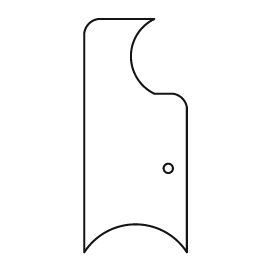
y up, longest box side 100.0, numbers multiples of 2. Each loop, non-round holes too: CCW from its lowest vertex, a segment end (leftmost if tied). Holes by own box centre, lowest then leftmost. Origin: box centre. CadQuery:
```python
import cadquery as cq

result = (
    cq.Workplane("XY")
    .moveTo(-22.0, -50.0)
    .threePointArc((0.0, -38.0), (22.0, -50.0))
    .lineTo(22.0, 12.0)
    .threePointArc((20.0, 16.0), (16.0, 18.0))
    .lineTo(8.0, 18.0)
    .threePointArc((-2.0, 34.0), (8.0, 50.0))
    .lineTo(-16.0, 50.0)
    .threePointArc((-20.0, 48.0), (-22.0, 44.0))
    .close()
    .moveTo(14.0, -14.0)
    .circle(2.0)
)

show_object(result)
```